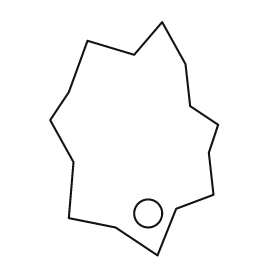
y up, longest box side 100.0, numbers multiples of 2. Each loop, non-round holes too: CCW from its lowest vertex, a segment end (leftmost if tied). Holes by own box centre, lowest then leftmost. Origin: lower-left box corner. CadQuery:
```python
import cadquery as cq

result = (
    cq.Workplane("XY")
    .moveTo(46.0, 0.0)
    .lineTo(54.0, 20.0)
    .lineTo(70.0, 26.0)
    .lineTo(68.0, 44.0)
    .lineTo(72.0, 56.0)
    .lineTo(60.0, 64.0)
    .lineTo(58.0, 82.0)
    .lineTo(48.0, 100.0)
    .lineTo(36.0, 86.0)
    .lineTo(16.0, 92.0)
    .lineTo(8.0, 70.0)
    .lineTo(0.0, 58.0)
    .lineTo(10.0, 40.0)
    .lineTo(8.0, 16.0)
    .lineTo(28.0, 12.0)
    .close()
    .moveTo(42.0, 18.0)
    .circle(6.0)
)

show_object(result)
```